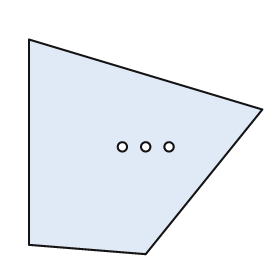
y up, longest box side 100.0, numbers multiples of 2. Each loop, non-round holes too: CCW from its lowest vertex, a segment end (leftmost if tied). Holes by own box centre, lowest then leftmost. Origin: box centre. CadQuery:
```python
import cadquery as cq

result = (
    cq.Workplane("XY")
    .moveTo(0.0, -46.0)
    .lineTo(50.0, 16.0)
    .lineTo(-50.0, 46.0)
    .lineTo(-50.0, -42.0)
    .close()
    .moveTo(-10.0, 0.0)
    .circle(2.0)
    .moveTo(0.0, 0.0)
    .circle(2.0)
    .moveTo(10.0, 0.0)
    .circle(2.0)
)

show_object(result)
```